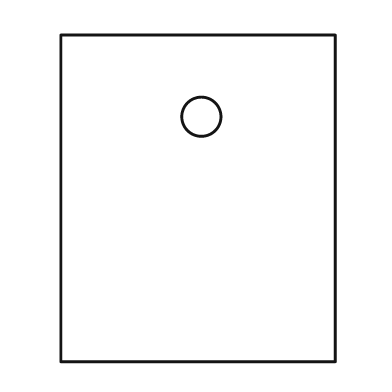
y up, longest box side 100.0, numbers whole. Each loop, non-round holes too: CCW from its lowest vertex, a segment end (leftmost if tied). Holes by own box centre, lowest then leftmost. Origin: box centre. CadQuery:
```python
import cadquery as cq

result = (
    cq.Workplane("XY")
    .moveTo(-42.0, -50.0)
    .lineTo(42.0, -50.0)
    .lineTo(42.0, 50.0)
    .lineTo(-42.0, 50.0)
    .close()
    .moveTo(1.0, 25.0)
    .circle(6.0)
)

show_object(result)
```